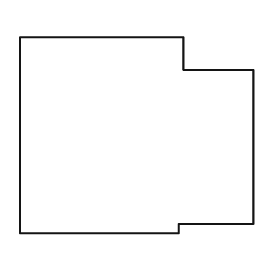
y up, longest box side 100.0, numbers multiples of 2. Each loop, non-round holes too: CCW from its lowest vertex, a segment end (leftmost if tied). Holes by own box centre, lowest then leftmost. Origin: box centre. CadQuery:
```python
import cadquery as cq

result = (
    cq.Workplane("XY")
    .moveTo(-50.0, -42.0)
    .lineTo(18.0, -42.0)
    .lineTo(18.0, -38.0)
    .lineTo(50.0, -38.0)
    .lineTo(50.0, 28.0)
    .lineTo(20.0, 28.0)
    .lineTo(20.0, 42.0)
    .lineTo(-50.0, 42.0)
    .close()
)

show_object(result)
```